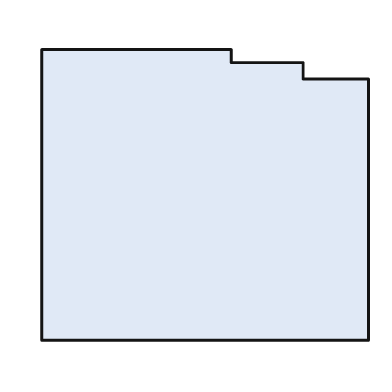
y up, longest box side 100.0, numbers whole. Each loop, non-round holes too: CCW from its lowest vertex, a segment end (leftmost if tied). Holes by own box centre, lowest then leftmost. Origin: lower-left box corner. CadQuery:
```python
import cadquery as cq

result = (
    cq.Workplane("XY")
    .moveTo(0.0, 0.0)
    .lineTo(100.0, 0.0)
    .lineTo(100.0, 80.0)
    .lineTo(80.0, 80.0)
    .lineTo(80.0, 85.0)
    .lineTo(58.0, 85.0)
    .lineTo(58.0, 89.0)
    .lineTo(0.0, 89.0)
    .close()
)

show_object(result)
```